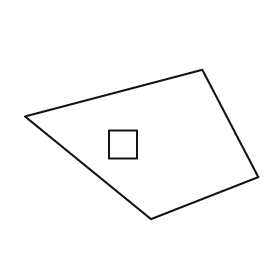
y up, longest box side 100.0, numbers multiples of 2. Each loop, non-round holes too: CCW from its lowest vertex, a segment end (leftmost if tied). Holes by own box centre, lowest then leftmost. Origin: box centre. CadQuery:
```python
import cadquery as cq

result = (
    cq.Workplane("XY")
    .moveTo(4.0, -32.0)
    .lineTo(50.0, -14.0)
    .lineTo(26.0, 32.0)
    .lineTo(-50.0, 12.0)
    .close()
    .moveTo(-14.0, -6.0)
    .lineTo(-2.0, -6.0)
    .lineTo(-2.0, 6.0)
    .lineTo(-14.0, 6.0)
    .close()
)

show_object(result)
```